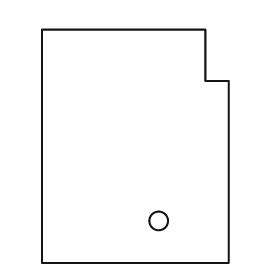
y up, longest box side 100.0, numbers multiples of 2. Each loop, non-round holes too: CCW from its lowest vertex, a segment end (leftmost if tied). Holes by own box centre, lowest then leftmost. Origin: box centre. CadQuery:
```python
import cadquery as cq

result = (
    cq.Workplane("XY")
    .moveTo(-40.0, -50.0)
    .lineTo(40.0, -50.0)
    .lineTo(40.0, 28.0)
    .lineTo(30.0, 28.0)
    .lineTo(30.0, 50.0)
    .lineTo(-40.0, 50.0)
    .close()
    .moveTo(10.0, -32.0)
    .circle(4.0)
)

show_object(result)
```